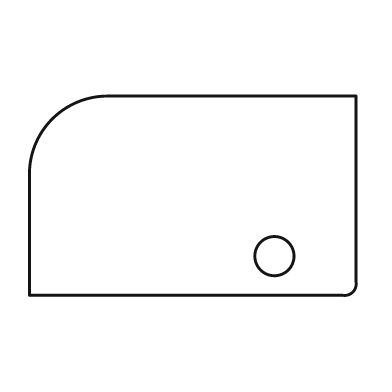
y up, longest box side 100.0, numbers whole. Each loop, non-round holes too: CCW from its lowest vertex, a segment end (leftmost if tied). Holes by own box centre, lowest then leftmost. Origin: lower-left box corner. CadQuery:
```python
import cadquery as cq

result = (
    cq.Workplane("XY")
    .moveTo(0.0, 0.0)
    .lineTo(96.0, 0.0)
    .threePointArc((99.0, 1.0), (100.0, 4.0))
    .lineTo(100.0, 61.0)
    .lineTo(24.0, 61.0)
    .threePointArc((7.0, 54.0), (0.0, 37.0))
    .close()
    .moveTo(75.0, 12.0)
    .circle(6.0)
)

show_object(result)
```